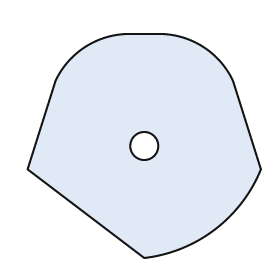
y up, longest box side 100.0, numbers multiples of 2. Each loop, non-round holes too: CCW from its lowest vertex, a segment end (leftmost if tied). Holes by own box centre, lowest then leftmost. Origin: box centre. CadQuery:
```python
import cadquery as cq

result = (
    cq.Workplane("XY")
    .moveTo(0.0, -48.0)
    .threePointArc((30.0, -36.0), (50.0, -10.0))
    .lineTo(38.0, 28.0)
    .threePointArc((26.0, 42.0), (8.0, 48.0))
    .lineTo(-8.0, 48.0)
    .threePointArc((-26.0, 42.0), (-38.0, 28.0))
    .lineTo(-50.0, -10.0)
    .close()
    .moveTo(0.0, 0.0)
    .circle(6.0)
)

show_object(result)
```